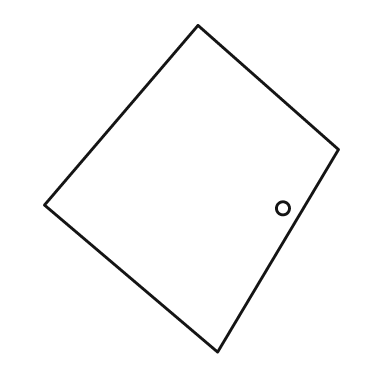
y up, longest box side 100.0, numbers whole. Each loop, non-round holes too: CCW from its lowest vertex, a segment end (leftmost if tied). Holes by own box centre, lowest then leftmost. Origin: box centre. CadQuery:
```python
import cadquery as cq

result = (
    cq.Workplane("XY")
    .moveTo(8.0, -50.0)
    .lineTo(45.0, 12.0)
    .lineTo(2.0, 50.0)
    .lineTo(-45.0, -5.0)
    .close()
    .moveTo(28.0, -6.0)
    .circle(2.0)
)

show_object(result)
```